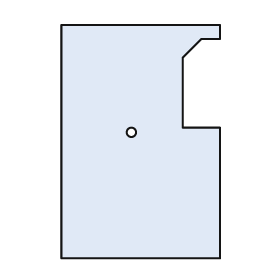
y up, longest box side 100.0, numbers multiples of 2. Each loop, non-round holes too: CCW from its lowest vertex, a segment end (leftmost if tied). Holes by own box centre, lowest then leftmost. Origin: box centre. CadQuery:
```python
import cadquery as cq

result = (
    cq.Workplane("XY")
    .moveTo(-34.0, -50.0)
    .lineTo(34.0, -50.0)
    .lineTo(34.0, 6.0)
    .lineTo(18.0, 6.0)
    .lineTo(18.0, 36.0)
    .lineTo(26.0, 44.0)
    .lineTo(34.0, 44.0)
    .lineTo(34.0, 50.0)
    .lineTo(-34.0, 50.0)
    .close()
    .moveTo(-4.0, 4.0)
    .circle(2.0)
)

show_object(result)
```